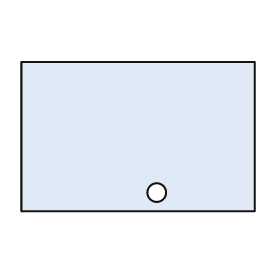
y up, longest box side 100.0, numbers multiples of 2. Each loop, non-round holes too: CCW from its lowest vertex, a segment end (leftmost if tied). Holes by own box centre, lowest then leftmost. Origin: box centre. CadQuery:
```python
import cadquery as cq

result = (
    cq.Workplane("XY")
    .moveTo(-50.0, -32.0)
    .lineTo(50.0, -32.0)
    .lineTo(50.0, 32.0)
    .lineTo(-50.0, 32.0)
    .close()
    .moveTo(8.0, -24.0)
    .circle(4.0)
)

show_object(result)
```